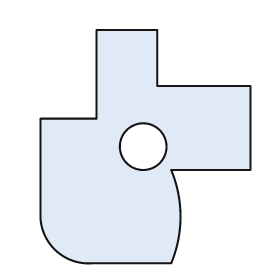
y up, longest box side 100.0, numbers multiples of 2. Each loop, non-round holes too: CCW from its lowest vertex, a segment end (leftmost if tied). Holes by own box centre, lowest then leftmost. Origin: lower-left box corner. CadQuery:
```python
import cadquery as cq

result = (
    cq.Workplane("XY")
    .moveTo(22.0, 0.0)
    .lineTo(56.0, 0.0)
    .threePointArc((60.0, 20.0), (56.0, 40.0))
    .lineTo(90.0, 40.0)
    .lineTo(90.0, 76.0)
    .lineTo(50.0, 76.0)
    .lineTo(50.0, 100.0)
    .lineTo(24.0, 100.0)
    .lineTo(24.0, 62.0)
    .lineTo(0.0, 62.0)
    .lineTo(0.0, 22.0)
    .threePointArc((6.0, 6.0), (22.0, 0.0))
    .close()
    .moveTo(44.0, 50.0)
    .circle(10.0)
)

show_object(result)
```